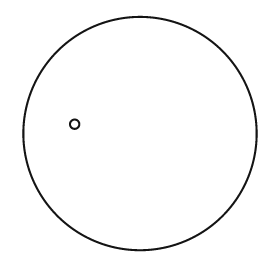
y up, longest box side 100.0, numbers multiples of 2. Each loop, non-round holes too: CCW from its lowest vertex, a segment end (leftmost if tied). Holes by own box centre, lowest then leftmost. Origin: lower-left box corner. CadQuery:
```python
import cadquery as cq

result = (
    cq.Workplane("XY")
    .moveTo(50.0, 50.0)
    .circle(50.0)
    .moveTo(22.0, 54.0)
    .circle(2.0)
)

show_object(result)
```